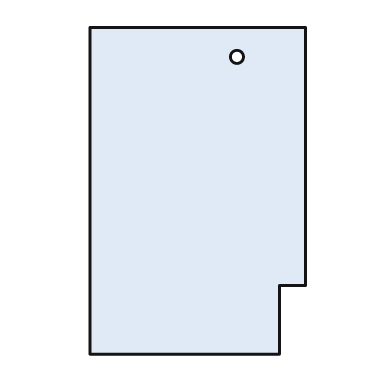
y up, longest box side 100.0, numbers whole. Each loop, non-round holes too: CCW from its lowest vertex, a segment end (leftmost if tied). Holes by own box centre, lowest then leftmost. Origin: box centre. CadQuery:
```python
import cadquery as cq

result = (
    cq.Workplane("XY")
    .moveTo(-33.0, -50.0)
    .lineTo(25.0, -50.0)
    .lineTo(25.0, -29.0)
    .lineTo(33.0, -29.0)
    .lineTo(33.0, 50.0)
    .lineTo(-33.0, 50.0)
    .close()
    .moveTo(12.0, 41.0)
    .circle(2.0)
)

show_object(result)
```